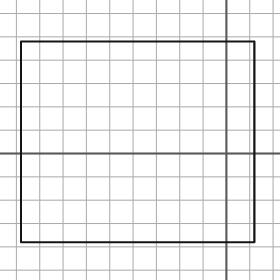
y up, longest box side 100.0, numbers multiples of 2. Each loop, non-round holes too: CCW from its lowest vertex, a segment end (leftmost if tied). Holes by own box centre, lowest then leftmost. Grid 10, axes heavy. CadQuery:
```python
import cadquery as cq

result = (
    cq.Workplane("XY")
    .moveTo(-88.0, -38.0)
    .lineTo(12.0, -38.0)
    .lineTo(12.0, 48.0)
    .lineTo(-88.0, 48.0)
    .close()
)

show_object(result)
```